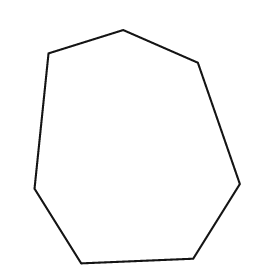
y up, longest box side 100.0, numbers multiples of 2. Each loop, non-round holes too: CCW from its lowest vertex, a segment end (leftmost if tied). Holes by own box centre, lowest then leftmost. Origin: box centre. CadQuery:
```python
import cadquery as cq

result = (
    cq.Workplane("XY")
    .moveTo(-24.0, -50.0)
    .lineTo(24.0, -48.0)
    .lineTo(44.0, -16.0)
    .lineTo(26.0, 36.0)
    .lineTo(-6.0, 50.0)
    .lineTo(-38.0, 40.0)
    .lineTo(-44.0, -18.0)
    .close()
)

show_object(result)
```